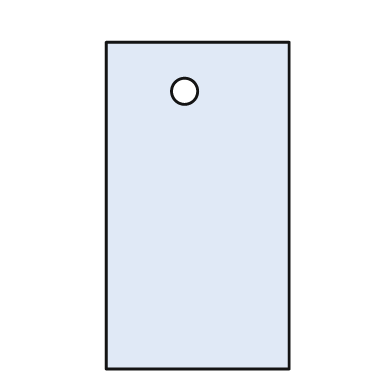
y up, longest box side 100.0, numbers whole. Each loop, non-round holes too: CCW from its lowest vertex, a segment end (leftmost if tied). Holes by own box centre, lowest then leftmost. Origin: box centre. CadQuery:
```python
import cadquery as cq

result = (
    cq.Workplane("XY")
    .moveTo(-28.0, -50.0)
    .lineTo(28.0, -50.0)
    .lineTo(28.0, 50.0)
    .lineTo(-28.0, 50.0)
    .close()
    .moveTo(-4.0, 35.0)
    .circle(4.0)
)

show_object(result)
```